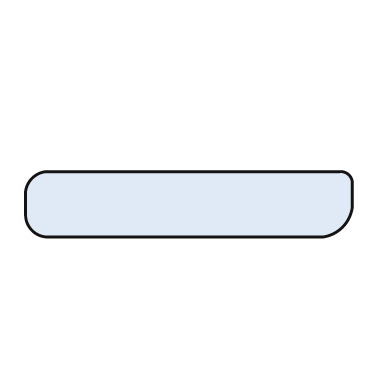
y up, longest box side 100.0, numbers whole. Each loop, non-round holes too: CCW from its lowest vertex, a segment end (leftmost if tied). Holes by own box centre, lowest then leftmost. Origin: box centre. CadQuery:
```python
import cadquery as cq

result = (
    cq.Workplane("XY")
    .moveTo(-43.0, -10.0)
    .lineTo(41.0, -10.0)
    .threePointArc((47.0, -7.0), (50.0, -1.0))
    .lineTo(50.0, 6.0)
    .threePointArc((49.0, 9.0), (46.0, 10.0))
    .lineTo(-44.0, 10.0)
    .threePointArc((-48.0, 8.0), (-50.0, 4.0))
    .lineTo(-50.0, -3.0)
    .threePointArc((-48.0, -8.0), (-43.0, -10.0))
    .close()
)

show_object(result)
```